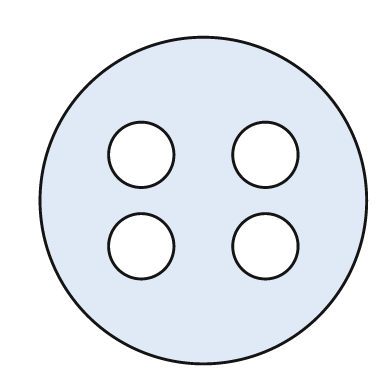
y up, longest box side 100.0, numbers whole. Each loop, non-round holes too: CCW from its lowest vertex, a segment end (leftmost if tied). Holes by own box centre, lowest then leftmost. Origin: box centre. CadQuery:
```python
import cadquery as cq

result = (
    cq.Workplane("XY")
    .moveTo(0.0, 0.0)
    .circle(50.0)
    .moveTo(-19.0, -14.0)
    .circle(10.0)
    .moveTo(19.0, -14.0)
    .circle(10.0)
    .moveTo(-19.0, 14.0)
    .circle(10.0)
    .moveTo(19.0, 14.0)
    .circle(10.0)
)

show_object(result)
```